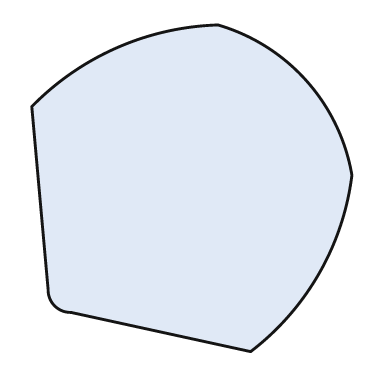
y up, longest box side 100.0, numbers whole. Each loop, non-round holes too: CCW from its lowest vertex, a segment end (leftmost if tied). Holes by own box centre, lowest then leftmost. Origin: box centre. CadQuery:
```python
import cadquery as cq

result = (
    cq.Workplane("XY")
    .moveTo(18.0, -50.0)
    .threePointArc((39.0, -26.0), (49.0, 4.0))
    .threePointArc((35.0, 33.0), (8.0, 50.0))
    .threePointArc((-23.0, 43.0), (-49.0, 25.0))
    .lineTo(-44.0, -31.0)
    .threePointArc((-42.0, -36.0), (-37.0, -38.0))
    .close()
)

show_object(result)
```